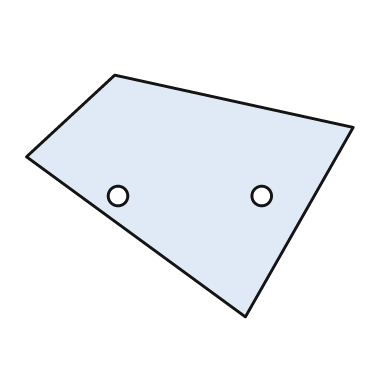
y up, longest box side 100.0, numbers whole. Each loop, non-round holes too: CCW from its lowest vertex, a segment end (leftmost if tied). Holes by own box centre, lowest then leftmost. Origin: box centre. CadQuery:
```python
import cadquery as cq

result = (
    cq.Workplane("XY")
    .moveTo(17.0, -37.0)
    .lineTo(50.0, 21.0)
    .lineTo(-23.0, 37.0)
    .lineTo(-50.0, 12.0)
    .close()
    .moveTo(-22.0, 0.0)
    .circle(3.0)
    .moveTo(22.0, 0.0)
    .circle(3.0)
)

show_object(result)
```